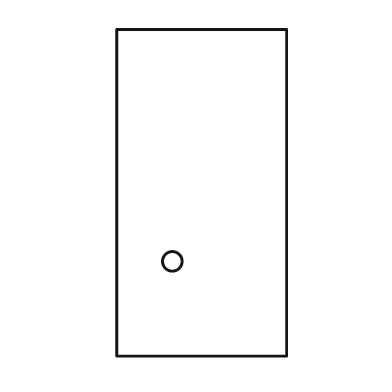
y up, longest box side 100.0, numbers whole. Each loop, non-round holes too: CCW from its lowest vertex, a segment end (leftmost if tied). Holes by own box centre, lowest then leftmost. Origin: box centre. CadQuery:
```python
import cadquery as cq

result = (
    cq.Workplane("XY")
    .moveTo(-26.0, -50.0)
    .lineTo(26.0, -50.0)
    .lineTo(26.0, 50.0)
    .lineTo(-26.0, 50.0)
    .close()
    .moveTo(-9.0, -21.0)
    .circle(3.0)
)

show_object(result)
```